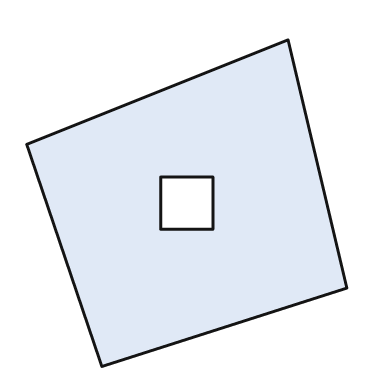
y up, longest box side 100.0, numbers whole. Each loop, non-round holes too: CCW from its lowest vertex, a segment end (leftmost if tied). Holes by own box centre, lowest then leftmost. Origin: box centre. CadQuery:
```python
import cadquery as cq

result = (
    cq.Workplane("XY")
    .moveTo(-26.0, -50.0)
    .lineTo(49.0, -26.0)
    .lineTo(31.0, 50.0)
    .lineTo(-49.0, 18.0)
    .close()
    .moveTo(-8.0, -8.0)
    .lineTo(8.0, -8.0)
    .lineTo(8.0, 8.0)
    .lineTo(-8.0, 8.0)
    .close()
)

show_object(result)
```